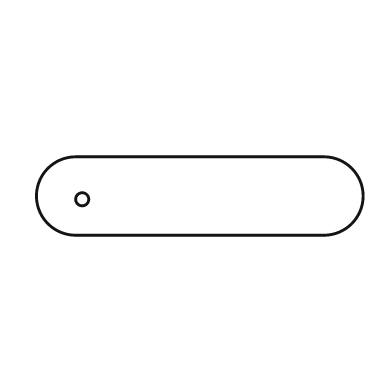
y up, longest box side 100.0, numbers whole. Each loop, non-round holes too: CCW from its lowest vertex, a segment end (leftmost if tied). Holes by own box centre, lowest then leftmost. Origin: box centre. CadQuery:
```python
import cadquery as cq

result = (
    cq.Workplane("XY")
    .moveTo(-38.0, -12.0)
    .lineTo(38.0, -12.0)
    .threePointArc((50.0, 0.0), (38.0, 12.0))
    .lineTo(-38.0, 12.0)
    .threePointArc((-50.0, 0.0), (-38.0, -12.0))
    .close()
    .moveTo(-36.0, -1.0)
    .circle(2.0)
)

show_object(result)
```